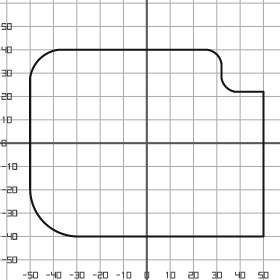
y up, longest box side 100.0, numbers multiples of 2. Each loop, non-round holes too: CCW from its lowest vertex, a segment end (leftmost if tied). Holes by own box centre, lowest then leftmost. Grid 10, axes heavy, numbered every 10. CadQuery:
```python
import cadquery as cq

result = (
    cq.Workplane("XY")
    .moveTo(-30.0, -40.0)
    .lineTo(50.0, -40.0)
    .lineTo(50.0, 22.0)
    .lineTo(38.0, 22.0)
    .threePointArc((34.0, 24.0), (32.0, 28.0))
    .lineTo(32.0, 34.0)
    .threePointArc((30.0, 38.0), (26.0, 40.0))
    .lineTo(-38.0, 40.0)
    .threePointArc((-46.0, 36.0), (-50.0, 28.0))
    .lineTo(-50.0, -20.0)
    .threePointArc((-44.0, -34.0), (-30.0, -40.0))
    .close()
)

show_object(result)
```